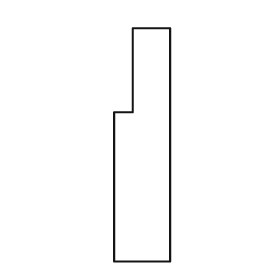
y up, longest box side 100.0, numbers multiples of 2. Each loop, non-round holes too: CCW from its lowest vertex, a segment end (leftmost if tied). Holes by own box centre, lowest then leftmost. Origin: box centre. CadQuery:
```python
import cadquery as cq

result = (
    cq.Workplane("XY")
    .moveTo(-12.0, -50.0)
    .lineTo(12.0, -50.0)
    .lineTo(12.0, 50.0)
    .lineTo(-4.0, 50.0)
    .lineTo(-4.0, 14.0)
    .lineTo(-12.0, 14.0)
    .close()
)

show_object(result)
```